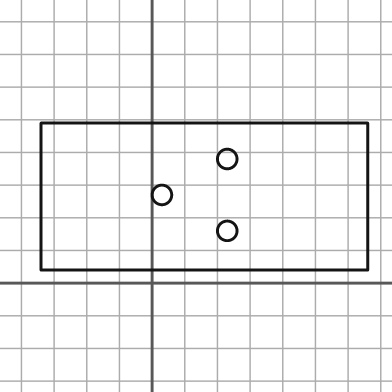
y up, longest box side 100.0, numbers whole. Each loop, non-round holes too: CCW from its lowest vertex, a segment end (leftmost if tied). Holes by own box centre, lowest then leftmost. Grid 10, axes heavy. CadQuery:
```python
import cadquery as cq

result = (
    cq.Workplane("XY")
    .moveTo(-34.0, 4.0)
    .lineTo(66.0, 4.0)
    .lineTo(66.0, 49.0)
    .lineTo(-34.0, 49.0)
    .close()
    .moveTo(23.0, 16.0)
    .circle(3.0)
    .moveTo(3.0, 27.0)
    .circle(3.0)
    .moveTo(23.0, 38.0)
    .circle(3.0)
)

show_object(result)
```